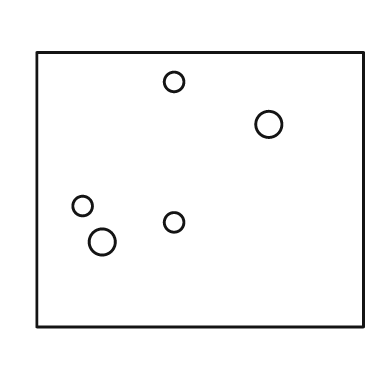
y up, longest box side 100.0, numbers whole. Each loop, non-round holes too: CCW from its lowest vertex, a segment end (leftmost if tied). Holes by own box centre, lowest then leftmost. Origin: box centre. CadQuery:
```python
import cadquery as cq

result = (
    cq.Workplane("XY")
    .moveTo(-50.0, -42.0)
    .lineTo(50.0, -42.0)
    .lineTo(50.0, 42.0)
    .lineTo(-50.0, 42.0)
    .close()
    .moveTo(-30.0, -16.0)
    .circle(4.0)
    .moveTo(-8.0, -10.0)
    .circle(3.0)
    .moveTo(-36.0, -5.0)
    .circle(3.0)
    .moveTo(21.0, 20.0)
    .circle(4.0)
    .moveTo(-8.0, 33.0)
    .circle(3.0)
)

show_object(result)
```